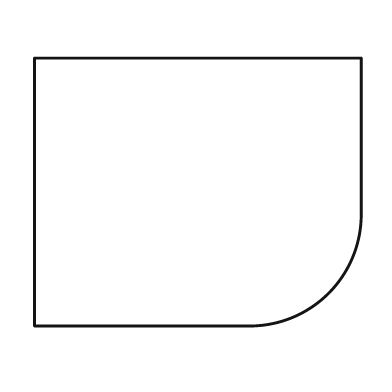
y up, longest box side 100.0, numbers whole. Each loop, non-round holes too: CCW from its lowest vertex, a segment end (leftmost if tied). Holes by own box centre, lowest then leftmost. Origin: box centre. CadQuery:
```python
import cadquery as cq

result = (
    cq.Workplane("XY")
    .moveTo(-50.0, -41.0)
    .lineTo(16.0, -41.0)
    .threePointArc((40.0, -31.0), (50.0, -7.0))
    .lineTo(50.0, 41.0)
    .lineTo(-50.0, 41.0)
    .close()
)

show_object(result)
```